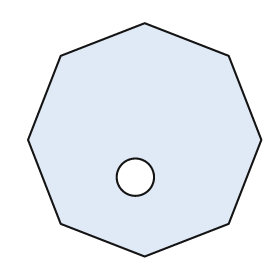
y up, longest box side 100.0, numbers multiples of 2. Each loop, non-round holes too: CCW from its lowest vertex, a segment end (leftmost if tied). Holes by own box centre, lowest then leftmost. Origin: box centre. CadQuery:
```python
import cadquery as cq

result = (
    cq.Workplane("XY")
    .moveTo(0.0, -50.0)
    .lineTo(36.0, -36.0)
    .lineTo(50.0, 0.0)
    .lineTo(36.0, 36.0)
    .lineTo(0.0, 50.0)
    .lineTo(-36.0, 36.0)
    .lineTo(-50.0, 0.0)
    .lineTo(-36.0, -36.0)
    .close()
    .moveTo(-4.0, -16.0)
    .circle(8.0)
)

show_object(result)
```